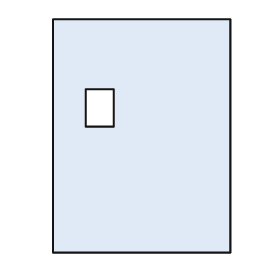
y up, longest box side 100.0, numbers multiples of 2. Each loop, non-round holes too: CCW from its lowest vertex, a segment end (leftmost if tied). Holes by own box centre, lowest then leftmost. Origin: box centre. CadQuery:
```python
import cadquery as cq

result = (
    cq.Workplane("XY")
    .moveTo(-38.0, -50.0)
    .lineTo(38.0, -50.0)
    .lineTo(38.0, 50.0)
    .lineTo(-38.0, 50.0)
    .close()
    .moveTo(-24.0, 4.0)
    .lineTo(-12.0, 4.0)
    .lineTo(-12.0, 20.0)
    .lineTo(-24.0, 20.0)
    .close()
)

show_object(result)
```